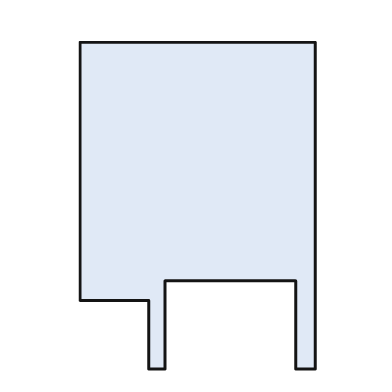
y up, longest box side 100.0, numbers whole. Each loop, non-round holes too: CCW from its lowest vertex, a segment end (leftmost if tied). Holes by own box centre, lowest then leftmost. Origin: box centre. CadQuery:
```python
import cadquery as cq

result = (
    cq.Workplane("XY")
    .moveTo(-15.0, -50.0)
    .lineTo(-10.0, -50.0)
    .lineTo(-10.0, -23.0)
    .lineTo(30.0, -23.0)
    .lineTo(30.0, -50.0)
    .lineTo(36.0, -50.0)
    .lineTo(36.0, 50.0)
    .lineTo(-36.0, 50.0)
    .lineTo(-36.0, -29.0)
    .lineTo(-15.0, -29.0)
    .close()
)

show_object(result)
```